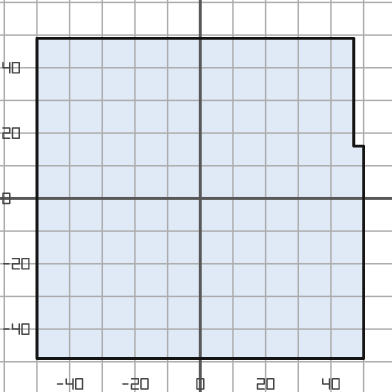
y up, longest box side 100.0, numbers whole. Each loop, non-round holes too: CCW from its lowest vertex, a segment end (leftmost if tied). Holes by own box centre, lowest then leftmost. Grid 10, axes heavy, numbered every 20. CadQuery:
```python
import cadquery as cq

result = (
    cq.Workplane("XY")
    .moveTo(-50.0, -49.0)
    .lineTo(50.0, -49.0)
    .lineTo(50.0, 16.0)
    .lineTo(47.0, 16.0)
    .lineTo(47.0, 49.0)
    .lineTo(-50.0, 49.0)
    .close()
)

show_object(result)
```